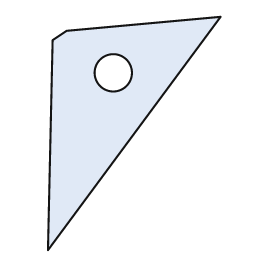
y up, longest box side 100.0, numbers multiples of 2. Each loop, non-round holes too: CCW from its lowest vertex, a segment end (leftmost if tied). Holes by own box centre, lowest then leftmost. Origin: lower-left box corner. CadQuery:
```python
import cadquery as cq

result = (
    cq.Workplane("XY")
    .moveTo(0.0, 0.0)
    .lineTo(74.0, 100.0)
    .lineTo(8.0, 94.0)
    .lineTo(2.0, 90.0)
    .close()
    .moveTo(28.0, 76.0)
    .circle(8.0)
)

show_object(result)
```